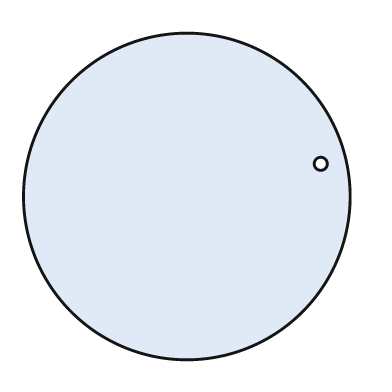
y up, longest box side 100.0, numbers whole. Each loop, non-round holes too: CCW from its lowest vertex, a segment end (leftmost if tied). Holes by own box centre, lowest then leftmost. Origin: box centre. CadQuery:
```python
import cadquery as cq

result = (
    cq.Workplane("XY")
    .moveTo(0.0, 0.0)
    .circle(50.0)
    .moveTo(41.0, 10.0)
    .circle(2.0)
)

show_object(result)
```